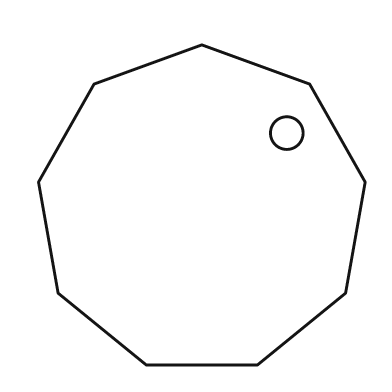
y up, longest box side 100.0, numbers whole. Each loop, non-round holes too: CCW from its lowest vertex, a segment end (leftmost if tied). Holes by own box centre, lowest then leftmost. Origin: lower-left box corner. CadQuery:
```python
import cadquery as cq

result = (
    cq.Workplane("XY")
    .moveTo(33.0, 0.0)
    .lineTo(67.0, 0.0)
    .lineTo(94.0, 22.0)
    .lineTo(100.0, 56.0)
    .lineTo(83.0, 86.0)
    .lineTo(50.0, 98.0)
    .lineTo(17.0, 86.0)
    .lineTo(0.0, 56.0)
    .lineTo(6.0, 22.0)
    .close()
    .moveTo(76.0, 71.0)
    .circle(5.0)
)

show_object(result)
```